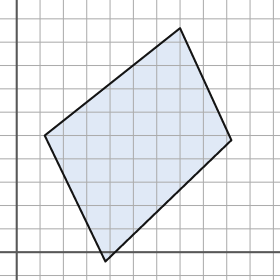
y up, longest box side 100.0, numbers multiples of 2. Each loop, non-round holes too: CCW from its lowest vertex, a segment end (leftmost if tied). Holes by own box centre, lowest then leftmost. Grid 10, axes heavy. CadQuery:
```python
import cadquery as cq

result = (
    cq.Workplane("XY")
    .moveTo(38.0, -4.0)
    .lineTo(92.0, 48.0)
    .lineTo(70.0, 96.0)
    .lineTo(12.0, 50.0)
    .close()
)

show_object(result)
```